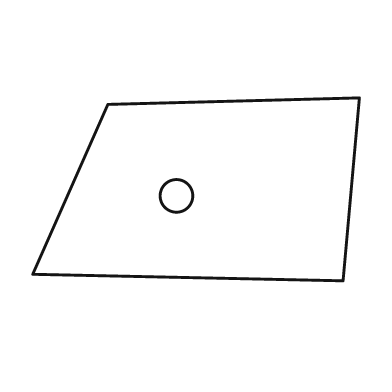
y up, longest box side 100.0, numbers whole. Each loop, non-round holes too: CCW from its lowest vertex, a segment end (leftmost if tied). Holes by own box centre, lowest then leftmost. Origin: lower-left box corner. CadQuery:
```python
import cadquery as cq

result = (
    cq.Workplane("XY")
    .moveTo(95.0, 0.0)
    .lineTo(100.0, 56.0)
    .lineTo(23.0, 54.0)
    .lineTo(0.0, 2.0)
    .close()
    .moveTo(44.0, 26.0)
    .circle(5.0)
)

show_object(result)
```